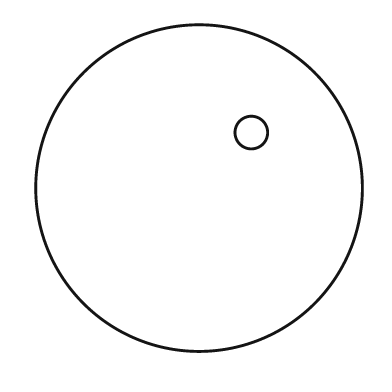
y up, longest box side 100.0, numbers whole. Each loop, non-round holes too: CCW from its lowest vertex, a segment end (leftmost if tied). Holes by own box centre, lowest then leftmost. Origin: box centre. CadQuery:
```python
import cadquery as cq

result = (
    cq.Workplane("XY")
    .moveTo(0.0, 0.0)
    .circle(50.0)
    .moveTo(16.0, 17.0)
    .circle(5.0)
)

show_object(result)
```